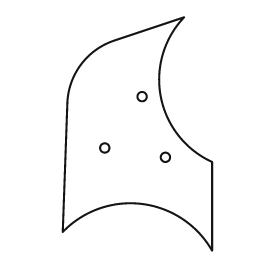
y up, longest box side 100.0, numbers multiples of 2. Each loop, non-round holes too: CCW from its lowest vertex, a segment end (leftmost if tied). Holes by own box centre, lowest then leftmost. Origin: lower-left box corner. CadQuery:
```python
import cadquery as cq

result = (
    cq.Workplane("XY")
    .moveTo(64.0, 0.0)
    .lineTo(64.0, 38.0)
    .threePointArc((42.0, 66.0), (52.0, 100.0))
    .lineTo(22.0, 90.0)
    .threePointArc((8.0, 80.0), (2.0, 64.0))
    .lineTo(0.0, 8.0)
    .threePointArc((34.0, 20.0), (64.0, 0.0))
    .close()
    .moveTo(44.0, 40.0)
    .circle(2.0)
    .moveTo(18.0, 44.0)
    .circle(2.0)
    .moveTo(34.0, 66.0)
    .circle(2.0)
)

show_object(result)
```